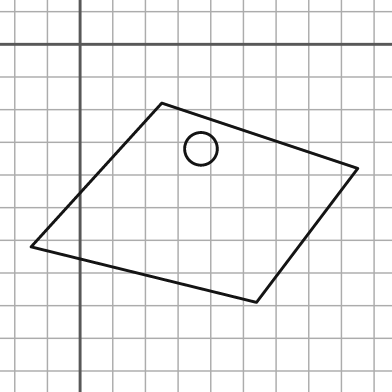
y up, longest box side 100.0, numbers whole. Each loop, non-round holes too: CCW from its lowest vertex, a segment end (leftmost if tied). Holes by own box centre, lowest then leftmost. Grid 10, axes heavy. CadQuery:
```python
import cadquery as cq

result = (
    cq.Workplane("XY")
    .moveTo(54.0, -79.0)
    .lineTo(85.0, -38.0)
    .lineTo(25.0, -18.0)
    .lineTo(-15.0, -62.0)
    .close()
    .moveTo(37.0, -32.0)
    .circle(5.0)
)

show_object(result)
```